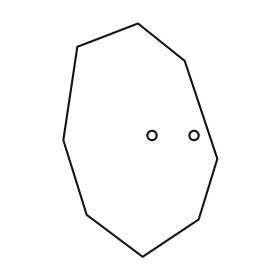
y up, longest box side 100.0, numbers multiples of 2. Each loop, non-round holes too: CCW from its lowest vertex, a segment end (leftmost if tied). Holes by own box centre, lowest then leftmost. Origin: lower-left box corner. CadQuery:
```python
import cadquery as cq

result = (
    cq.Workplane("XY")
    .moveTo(34.0, 0.0)
    .lineTo(58.0, 16.0)
    .lineTo(66.0, 42.0)
    .lineTo(52.0, 84.0)
    .lineTo(32.0, 100.0)
    .lineTo(6.0, 90.0)
    .lineTo(0.0, 50.0)
    .lineTo(10.0, 18.0)
    .close()
    .moveTo(38.0, 52.0)
    .circle(2.0)
    .moveTo(56.0, 52.0)
    .circle(2.0)
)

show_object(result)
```